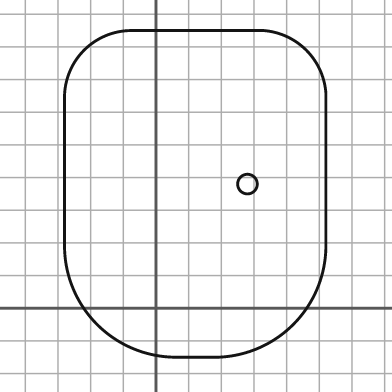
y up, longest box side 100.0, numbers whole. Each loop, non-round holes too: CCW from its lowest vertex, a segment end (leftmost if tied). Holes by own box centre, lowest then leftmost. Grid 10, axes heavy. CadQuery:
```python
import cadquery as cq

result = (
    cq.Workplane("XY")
    .moveTo(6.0, -15.0)
    .lineTo(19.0, -15.0)
    .threePointArc((42.0, -5.0), (52.0, 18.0))
    .lineTo(52.0, 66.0)
    .threePointArc((46.0, 79.0), (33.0, 85.0))
    .lineTo(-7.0, 85.0)
    .threePointArc((-22.0, 79.0), (-28.0, 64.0))
    .lineTo(-28.0, 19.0)
    .threePointArc((-18.0, -5.0), (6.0, -15.0))
    .close()
    .moveTo(28.0, 38.0)
    .circle(3.0)
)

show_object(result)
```